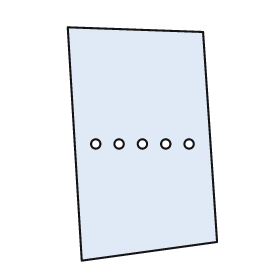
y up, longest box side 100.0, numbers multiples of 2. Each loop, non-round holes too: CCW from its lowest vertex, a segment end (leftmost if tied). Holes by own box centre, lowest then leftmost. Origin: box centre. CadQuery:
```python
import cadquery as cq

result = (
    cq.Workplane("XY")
    .moveTo(-26.0, -50.0)
    .lineTo(32.0, -42.0)
    .lineTo(26.0, 48.0)
    .lineTo(-32.0, 50.0)
    .close()
    .moveTo(-20.0, 0.0)
    .circle(2.0)
    .moveTo(-10.0, 0.0)
    .circle(2.0)
    .moveTo(0.0, 0.0)
    .circle(2.0)
    .moveTo(10.0, 0.0)
    .circle(2.0)
    .moveTo(20.0, 0.0)
    .circle(2.0)
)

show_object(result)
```